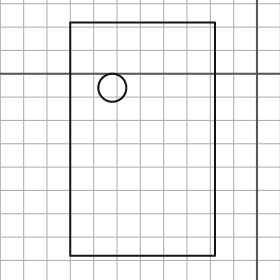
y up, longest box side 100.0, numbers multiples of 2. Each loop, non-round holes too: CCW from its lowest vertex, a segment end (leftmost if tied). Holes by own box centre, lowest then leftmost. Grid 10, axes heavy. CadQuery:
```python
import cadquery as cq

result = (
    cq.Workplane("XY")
    .moveTo(-80.0, -78.0)
    .lineTo(-18.0, -78.0)
    .lineTo(-18.0, 22.0)
    .lineTo(-80.0, 22.0)
    .close()
    .moveTo(-62.0, -6.0)
    .circle(6.0)
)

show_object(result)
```